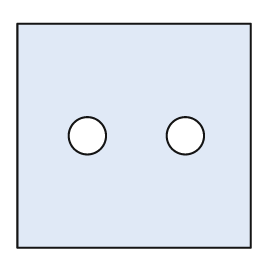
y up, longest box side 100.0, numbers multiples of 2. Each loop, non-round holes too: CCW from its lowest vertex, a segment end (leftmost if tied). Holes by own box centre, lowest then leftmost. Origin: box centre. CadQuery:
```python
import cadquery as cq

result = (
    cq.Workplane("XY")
    .moveTo(-50.0, -48.0)
    .lineTo(50.0, -48.0)
    .lineTo(50.0, 48.0)
    .lineTo(-50.0, 48.0)
    .close()
    .moveTo(-20.0, 0.0)
    .circle(8.0)
    .moveTo(22.0, 0.0)
    .circle(8.0)
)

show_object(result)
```